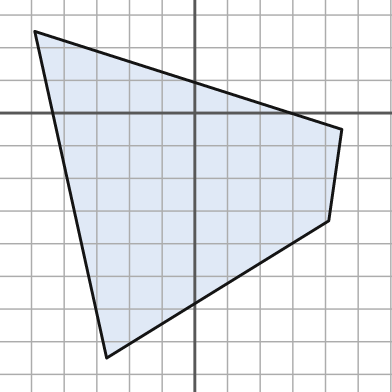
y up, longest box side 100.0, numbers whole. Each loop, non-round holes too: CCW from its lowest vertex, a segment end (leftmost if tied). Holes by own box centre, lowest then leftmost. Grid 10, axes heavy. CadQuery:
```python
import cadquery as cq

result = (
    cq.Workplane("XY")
    .moveTo(-27.0, -75.0)
    .lineTo(41.0, -33.0)
    .lineTo(45.0, -5.0)
    .lineTo(-49.0, 25.0)
    .close()
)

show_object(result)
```